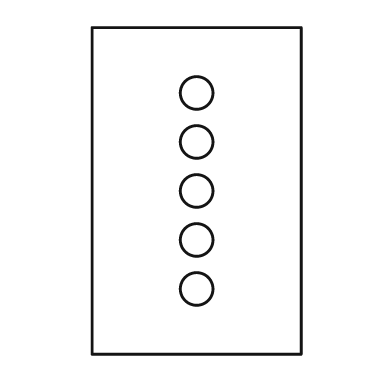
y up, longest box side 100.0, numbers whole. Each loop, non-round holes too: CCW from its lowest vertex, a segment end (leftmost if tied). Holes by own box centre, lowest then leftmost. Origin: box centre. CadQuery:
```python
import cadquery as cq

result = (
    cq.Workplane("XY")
    .moveTo(-32.0, -50.0)
    .lineTo(32.0, -50.0)
    .lineTo(32.0, 50.0)
    .lineTo(-32.0, 50.0)
    .close()
    .moveTo(0.0, -30.0)
    .circle(5.0)
    .moveTo(0.0, -15.0)
    .circle(5.0)
    .moveTo(0.0, 0.0)
    .circle(5.0)
    .moveTo(0.0, 15.0)
    .circle(5.0)
    .moveTo(0.0, 30.0)
    .circle(5.0)
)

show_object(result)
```